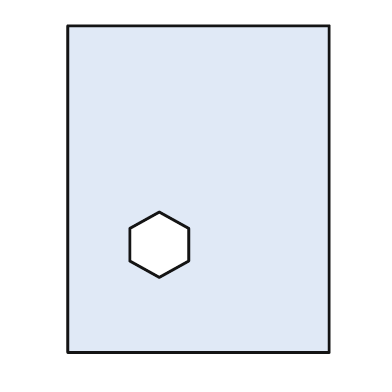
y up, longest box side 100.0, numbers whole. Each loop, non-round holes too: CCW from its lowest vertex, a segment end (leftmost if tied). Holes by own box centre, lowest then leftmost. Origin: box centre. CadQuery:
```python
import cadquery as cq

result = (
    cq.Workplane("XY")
    .moveTo(-40.0, -50.0)
    .lineTo(40.0, -50.0)
    .lineTo(40.0, 50.0)
    .lineTo(-40.0, 50.0)
    .close()
    .moveTo(-12.0, -27.0)
    .lineTo(-3.0, -22.0)
    .lineTo(-3.0, -12.0)
    .lineTo(-12.0, -7.0)
    .lineTo(-21.0, -12.0)
    .lineTo(-21.0, -22.0)
    .close()
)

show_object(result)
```